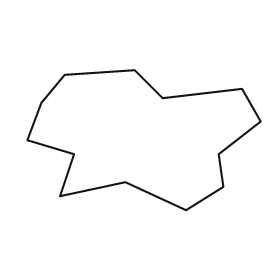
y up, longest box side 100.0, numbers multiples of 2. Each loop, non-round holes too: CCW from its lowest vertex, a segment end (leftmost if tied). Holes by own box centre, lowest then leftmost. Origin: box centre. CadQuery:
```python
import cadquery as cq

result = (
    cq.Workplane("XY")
    .moveTo(18.0, -30.0)
    .lineTo(34.0, -20.0)
    .lineTo(32.0, -6.0)
    .lineTo(50.0, 8.0)
    .lineTo(42.0, 22.0)
    .lineTo(8.0, 18.0)
    .lineTo(-4.0, 30.0)
    .lineTo(-34.0, 28.0)
    .lineTo(-44.0, 16.0)
    .lineTo(-50.0, 0.0)
    .lineTo(-30.0, -6.0)
    .lineTo(-36.0, -24.0)
    .lineTo(-8.0, -18.0)
    .close()
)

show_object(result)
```